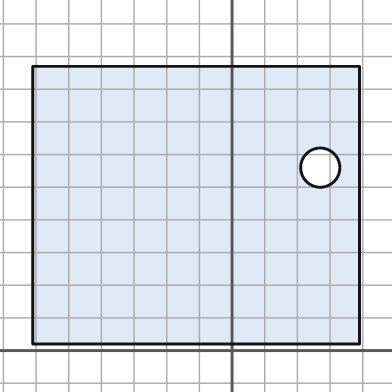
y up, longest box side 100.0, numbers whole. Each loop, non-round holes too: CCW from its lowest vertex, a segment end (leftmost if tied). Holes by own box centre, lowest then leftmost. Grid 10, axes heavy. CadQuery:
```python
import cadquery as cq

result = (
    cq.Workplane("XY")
    .moveTo(-61.0, 2.0)
    .lineTo(39.0, 2.0)
    .lineTo(39.0, 87.0)
    .lineTo(-61.0, 87.0)
    .close()
    .moveTo(27.0, 56.0)
    .circle(6.0)
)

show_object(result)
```